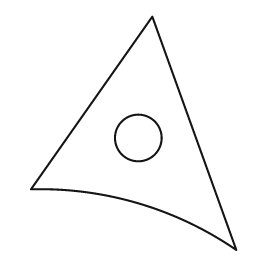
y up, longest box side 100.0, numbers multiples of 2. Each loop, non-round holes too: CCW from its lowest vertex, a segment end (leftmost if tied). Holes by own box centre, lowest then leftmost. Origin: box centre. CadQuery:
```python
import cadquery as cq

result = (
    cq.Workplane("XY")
    .moveTo(44.0, -50.0)
    .lineTo(8.0, 50.0)
    .lineTo(-44.0, -24.0)
    .threePointArc((2.0, -30.0), (44.0, -50.0))
    .close()
    .moveTo(2.0, -2.0)
    .circle(10.0)
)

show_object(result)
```